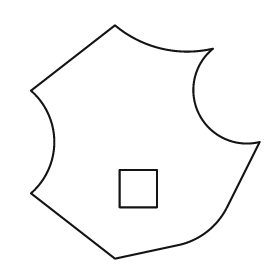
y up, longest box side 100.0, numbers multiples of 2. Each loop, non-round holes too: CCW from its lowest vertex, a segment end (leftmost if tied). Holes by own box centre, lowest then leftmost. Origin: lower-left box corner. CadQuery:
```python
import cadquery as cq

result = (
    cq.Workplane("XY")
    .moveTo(36.0, 0.0)
    .lineTo(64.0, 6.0)
    .threePointArc((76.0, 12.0), (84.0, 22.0))
    .lineTo(98.0, 50.0)
    .threePointArc((72.0, 62.0), (78.0, 90.0))
    .threePointArc((56.0, 90.0), (36.0, 100.0))
    .lineTo(0.0, 72.0)
    .threePointArc((10.0, 50.0), (0.0, 28.0))
    .close()
    .moveTo(38.0, 22.0)
    .lineTo(54.0, 22.0)
    .lineTo(54.0, 38.0)
    .lineTo(38.0, 38.0)
    .close()
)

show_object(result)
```